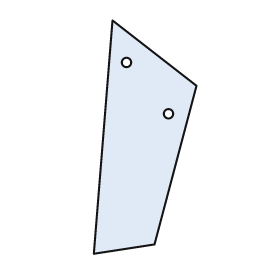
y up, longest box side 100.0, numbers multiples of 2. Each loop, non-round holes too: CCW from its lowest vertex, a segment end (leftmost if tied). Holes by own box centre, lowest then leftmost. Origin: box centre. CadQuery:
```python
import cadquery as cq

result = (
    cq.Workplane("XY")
    .moveTo(-22.0, -50.0)
    .lineTo(4.0, -46.0)
    .lineTo(22.0, 22.0)
    .lineTo(-14.0, 50.0)
    .close()
    .moveTo(10.0, 10.0)
    .circle(2.0)
    .moveTo(-8.0, 32.0)
    .circle(2.0)
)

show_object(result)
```